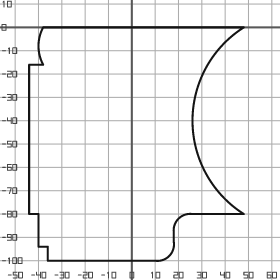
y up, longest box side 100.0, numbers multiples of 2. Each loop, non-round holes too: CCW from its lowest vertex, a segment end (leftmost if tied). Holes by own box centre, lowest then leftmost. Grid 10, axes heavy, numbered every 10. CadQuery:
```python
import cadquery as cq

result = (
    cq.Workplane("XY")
    .moveTo(-36.0, -100.0)
    .lineTo(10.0, -100.0)
    .threePointArc((16.0, -98.0), (18.0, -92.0))
    .lineTo(18.0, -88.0)
    .threePointArc((20.0, -82.0), (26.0, -80.0))
    .lineTo(48.0, -80.0)
    .threePointArc((26.0, -40.0), (48.0, 0.0))
    .lineTo(-38.0, 0.0)
    .threePointArc((-40.0, -8.0), (-38.0, -16.0))
    .lineTo(-44.0, -16.0)
    .lineTo(-44.0, -80.0)
    .lineTo(-40.0, -80.0)
    .lineTo(-40.0, -94.0)
    .lineTo(-36.0, -94.0)
    .close()
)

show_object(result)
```